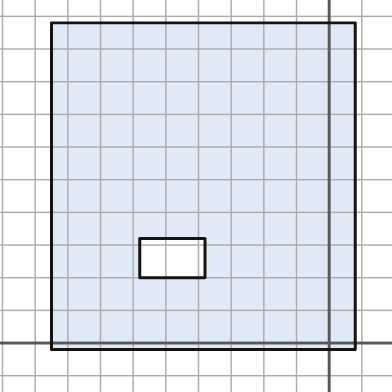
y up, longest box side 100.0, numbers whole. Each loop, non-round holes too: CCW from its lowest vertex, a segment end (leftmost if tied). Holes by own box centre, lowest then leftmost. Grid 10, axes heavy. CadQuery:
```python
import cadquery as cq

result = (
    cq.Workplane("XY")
    .moveTo(-85.0, -2.0)
    .lineTo(8.0, -2.0)
    .lineTo(8.0, 98.0)
    .lineTo(-85.0, 98.0)
    .close()
    .moveTo(-58.0, 20.0)
    .lineTo(-38.0, 20.0)
    .lineTo(-38.0, 32.0)
    .lineTo(-58.0, 32.0)
    .close()
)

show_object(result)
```